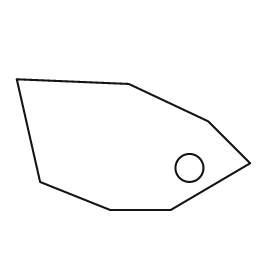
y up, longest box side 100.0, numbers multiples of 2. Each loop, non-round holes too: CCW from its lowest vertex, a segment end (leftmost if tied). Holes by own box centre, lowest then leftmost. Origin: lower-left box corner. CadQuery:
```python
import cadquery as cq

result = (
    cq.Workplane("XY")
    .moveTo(40.0, 0.0)
    .lineTo(66.0, 0.0)
    .lineTo(100.0, 20.0)
    .lineTo(82.0, 38.0)
    .lineTo(48.0, 54.0)
    .lineTo(0.0, 56.0)
    .lineTo(10.0, 12.0)
    .close()
    .moveTo(74.0, 18.0)
    .circle(6.0)
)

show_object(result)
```